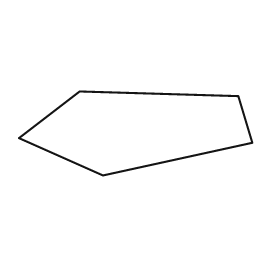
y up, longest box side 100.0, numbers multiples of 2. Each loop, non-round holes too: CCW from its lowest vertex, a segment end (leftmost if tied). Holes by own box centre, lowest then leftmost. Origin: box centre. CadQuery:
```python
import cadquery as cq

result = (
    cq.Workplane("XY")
    .moveTo(-14.0, -18.0)
    .lineTo(50.0, -4.0)
    .lineTo(44.0, 16.0)
    .lineTo(-24.0, 18.0)
    .lineTo(-50.0, -2.0)
    .close()
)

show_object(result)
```